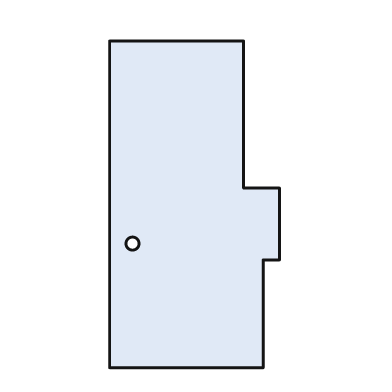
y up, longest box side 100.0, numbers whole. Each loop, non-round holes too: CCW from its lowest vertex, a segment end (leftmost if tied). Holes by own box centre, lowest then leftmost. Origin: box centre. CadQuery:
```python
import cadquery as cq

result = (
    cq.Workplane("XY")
    .moveTo(-26.0, -50.0)
    .lineTo(21.0, -50.0)
    .lineTo(21.0, -17.0)
    .lineTo(26.0, -17.0)
    .lineTo(26.0, 5.0)
    .lineTo(15.0, 5.0)
    .lineTo(15.0, 50.0)
    .lineTo(-26.0, 50.0)
    .close()
    .moveTo(-19.0, -12.0)
    .circle(2.0)
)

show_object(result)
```